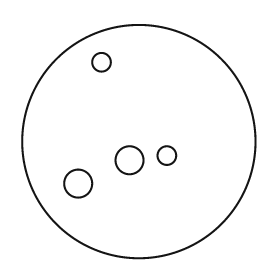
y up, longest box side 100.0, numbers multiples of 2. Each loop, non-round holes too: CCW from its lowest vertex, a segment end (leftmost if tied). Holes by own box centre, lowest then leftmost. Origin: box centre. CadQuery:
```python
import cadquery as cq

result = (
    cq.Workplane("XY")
    .moveTo(0.0, 0.0)
    .circle(50.0)
    .moveTo(-26.0, -18.0)
    .circle(6.0)
    .moveTo(-4.0, -8.0)
    .circle(6.0)
    .moveTo(12.0, -6.0)
    .circle(4.0)
    .moveTo(-16.0, 34.0)
    .circle(4.0)
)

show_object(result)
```